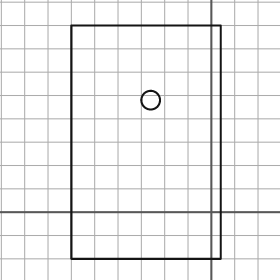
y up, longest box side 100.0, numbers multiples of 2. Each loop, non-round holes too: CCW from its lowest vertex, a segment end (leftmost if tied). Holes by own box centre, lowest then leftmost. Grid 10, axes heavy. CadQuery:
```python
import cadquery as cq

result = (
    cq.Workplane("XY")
    .moveTo(-60.0, -20.0)
    .lineTo(4.0, -20.0)
    .lineTo(4.0, 80.0)
    .lineTo(-60.0, 80.0)
    .close()
    .moveTo(-26.0, 48.0)
    .circle(4.0)
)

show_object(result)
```